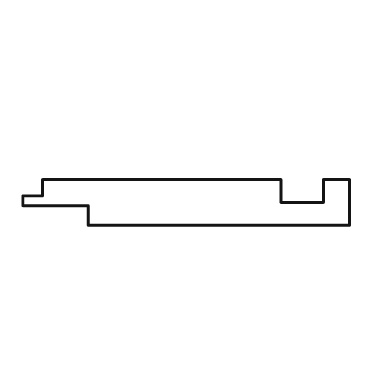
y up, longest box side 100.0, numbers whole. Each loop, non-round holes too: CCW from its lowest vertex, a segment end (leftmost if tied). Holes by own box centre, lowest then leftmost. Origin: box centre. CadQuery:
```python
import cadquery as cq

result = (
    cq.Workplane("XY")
    .moveTo(-30.0, -7.0)
    .lineTo(50.0, -7.0)
    .lineTo(50.0, 7.0)
    .lineTo(42.0, 7.0)
    .lineTo(42.0, 0.0)
    .lineTo(29.0, 0.0)
    .lineTo(29.0, 7.0)
    .lineTo(-44.0, 7.0)
    .lineTo(-44.0, 2.0)
    .lineTo(-50.0, 2.0)
    .lineTo(-50.0, -1.0)
    .lineTo(-30.0, -1.0)
    .close()
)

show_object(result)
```